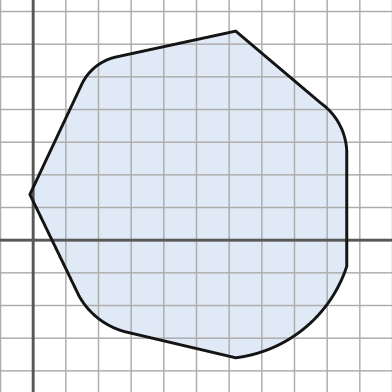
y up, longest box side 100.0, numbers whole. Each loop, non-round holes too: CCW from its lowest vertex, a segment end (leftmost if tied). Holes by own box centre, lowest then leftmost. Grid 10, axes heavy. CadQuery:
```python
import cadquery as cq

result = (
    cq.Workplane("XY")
    .moveTo(62.0, -36.0)
    .threePointArc((83.0, -27.0), (96.0, -8.0))
    .lineTo(96.0, 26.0)
    .threePointArc((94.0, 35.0), (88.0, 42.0))
    .lineTo(62.0, 64.0)
    .lineTo(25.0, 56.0)
    .threePointArc((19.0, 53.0), (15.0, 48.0))
    .lineTo(-1.0, 14.0)
    .lineTo(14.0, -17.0)
    .threePointArc((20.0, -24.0), (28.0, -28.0))
    .close()
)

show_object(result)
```